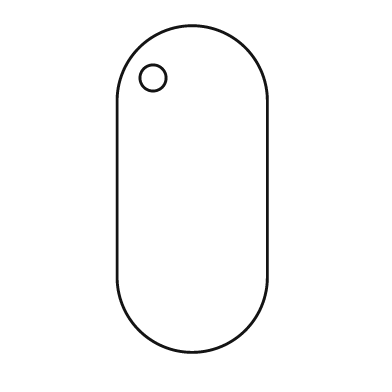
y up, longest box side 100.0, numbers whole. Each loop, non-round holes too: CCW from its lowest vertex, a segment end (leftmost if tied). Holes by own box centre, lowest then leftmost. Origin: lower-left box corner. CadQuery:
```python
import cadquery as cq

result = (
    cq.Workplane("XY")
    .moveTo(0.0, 23.0)
    .threePointArc((23.0, 0.0), (46.0, 23.0))
    .lineTo(46.0, 77.0)
    .threePointArc((23.0, 100.0), (0.0, 77.0))
    .close()
    .moveTo(11.0, 84.0)
    .circle(4.0)
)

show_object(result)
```